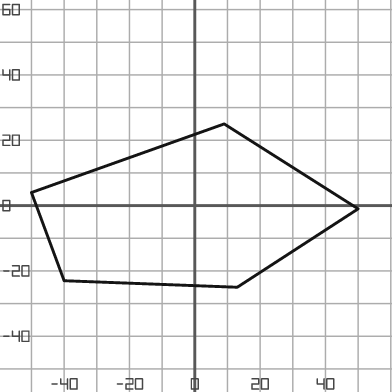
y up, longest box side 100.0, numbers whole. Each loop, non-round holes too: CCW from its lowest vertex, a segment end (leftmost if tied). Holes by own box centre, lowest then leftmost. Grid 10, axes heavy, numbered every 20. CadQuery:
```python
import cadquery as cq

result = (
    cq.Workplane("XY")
    .moveTo(13.0, -25.0)
    .lineTo(50.0, -1.0)
    .lineTo(9.0, 25.0)
    .lineTo(-50.0, 4.0)
    .lineTo(-40.0, -23.0)
    .close()
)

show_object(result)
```